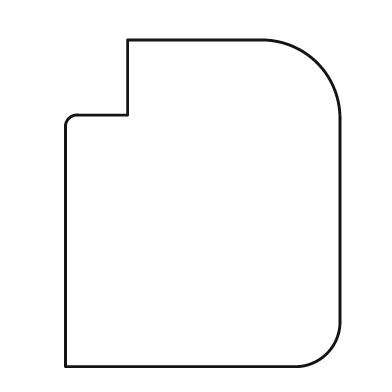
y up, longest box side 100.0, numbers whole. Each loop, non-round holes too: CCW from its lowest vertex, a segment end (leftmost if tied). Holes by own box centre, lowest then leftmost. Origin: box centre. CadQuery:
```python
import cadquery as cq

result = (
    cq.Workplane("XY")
    .moveTo(-42.0, -50.0)
    .lineTo(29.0, -50.0)
    .threePointArc((38.0, -46.0), (42.0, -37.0))
    .lineTo(42.0, 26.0)
    .threePointArc((35.0, 43.0), (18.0, 50.0))
    .lineTo(-23.0, 50.0)
    .lineTo(-23.0, 27.0)
    .lineTo(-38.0, 27.0)
    .threePointArc((-41.0, 26.0), (-42.0, 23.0))
    .close()
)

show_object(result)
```